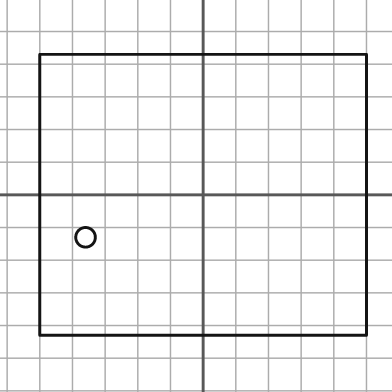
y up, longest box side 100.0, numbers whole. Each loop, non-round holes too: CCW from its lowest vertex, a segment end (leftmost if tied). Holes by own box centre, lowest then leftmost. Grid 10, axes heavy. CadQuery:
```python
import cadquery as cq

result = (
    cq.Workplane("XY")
    .moveTo(-50.0, -43.0)
    .lineTo(50.0, -43.0)
    .lineTo(50.0, 43.0)
    .lineTo(-50.0, 43.0)
    .close()
    .moveTo(-36.0, -13.0)
    .circle(3.0)
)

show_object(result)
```